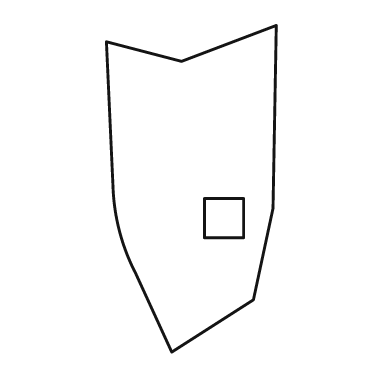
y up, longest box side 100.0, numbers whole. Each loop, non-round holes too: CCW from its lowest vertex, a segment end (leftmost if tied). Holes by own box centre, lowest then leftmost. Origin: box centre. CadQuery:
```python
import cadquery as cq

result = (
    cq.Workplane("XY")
    .moveTo(-6.0, -50.0)
    .lineTo(19.0, -34.0)
    .lineTo(25.0, -6.0)
    .lineTo(26.0, 50.0)
    .lineTo(-3.0, 39.0)
    .lineTo(-26.0, 45.0)
    .lineTo(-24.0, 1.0)
    .threePointArc((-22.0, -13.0), (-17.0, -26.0))
    .close()
    .moveTo(4.0, -15.0)
    .lineTo(16.0, -15.0)
    .lineTo(16.0, -3.0)
    .lineTo(4.0, -3.0)
    .close()
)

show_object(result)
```